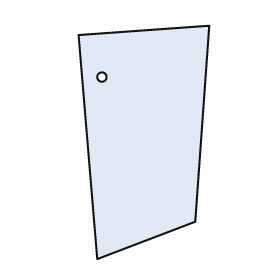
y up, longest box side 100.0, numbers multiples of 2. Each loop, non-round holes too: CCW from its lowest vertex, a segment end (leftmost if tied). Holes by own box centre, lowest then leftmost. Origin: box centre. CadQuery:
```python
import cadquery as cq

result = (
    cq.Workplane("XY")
    .moveTo(-20.0, -50.0)
    .lineTo(22.0, -34.0)
    .lineTo(28.0, 50.0)
    .lineTo(-28.0, 46.0)
    .close()
    .moveTo(-18.0, 28.0)
    .circle(2.0)
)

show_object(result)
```